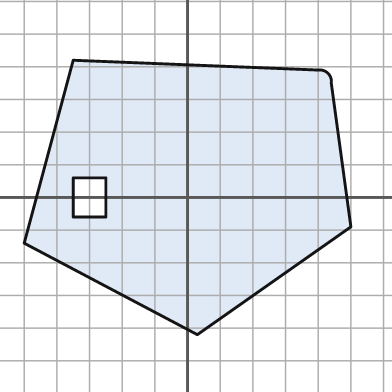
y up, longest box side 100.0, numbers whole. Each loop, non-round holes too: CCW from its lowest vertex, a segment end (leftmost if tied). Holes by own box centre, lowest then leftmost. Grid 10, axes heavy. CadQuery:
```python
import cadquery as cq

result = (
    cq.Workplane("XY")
    .moveTo(3.0, -42.0)
    .lineTo(50.0, -9.0)
    .lineTo(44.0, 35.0)
    .threePointArc((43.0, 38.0), (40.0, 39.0))
    .lineTo(-35.0, 42.0)
    .lineTo(-50.0, -14.0)
    .close()
    .moveTo(-35.0, -6.0)
    .lineTo(-25.0, -6.0)
    .lineTo(-25.0, 6.0)
    .lineTo(-35.0, 6.0)
    .close()
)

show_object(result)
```